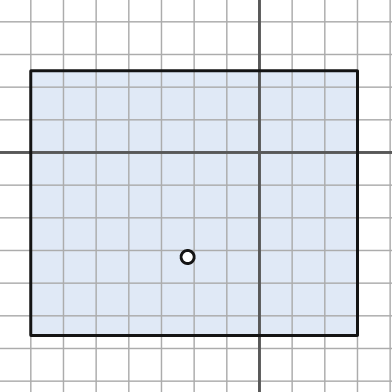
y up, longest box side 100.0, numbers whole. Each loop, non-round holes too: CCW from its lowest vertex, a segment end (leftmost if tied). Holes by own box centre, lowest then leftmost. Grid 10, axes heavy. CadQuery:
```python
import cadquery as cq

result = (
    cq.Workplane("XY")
    .moveTo(-70.0, -56.0)
    .lineTo(30.0, -56.0)
    .lineTo(30.0, 25.0)
    .lineTo(-70.0, 25.0)
    .close()
    .moveTo(-22.0, -32.0)
    .circle(2.0)
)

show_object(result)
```